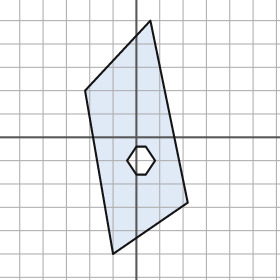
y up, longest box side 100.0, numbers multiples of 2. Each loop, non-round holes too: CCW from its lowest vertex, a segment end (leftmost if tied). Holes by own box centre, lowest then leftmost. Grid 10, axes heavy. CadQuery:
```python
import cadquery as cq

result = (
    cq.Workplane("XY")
    .moveTo(-10.0, -50.0)
    .lineTo(22.0, -28.0)
    .lineTo(6.0, 50.0)
    .lineTo(-22.0, 20.0)
    .close()
    .moveTo(0.0, -16.0)
    .lineTo(4.0, -16.0)
    .lineTo(8.0, -10.0)
    .lineTo(4.0, -4.0)
    .lineTo(0.0, -4.0)
    .lineTo(-4.0, -10.0)
    .close()
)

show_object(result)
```